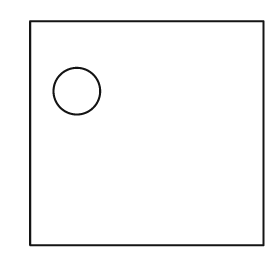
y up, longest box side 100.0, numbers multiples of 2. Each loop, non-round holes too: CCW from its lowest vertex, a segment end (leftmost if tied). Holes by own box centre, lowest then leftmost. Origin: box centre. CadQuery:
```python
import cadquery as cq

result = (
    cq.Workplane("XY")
    .moveTo(-50.0, -48.0)
    .lineTo(50.0, -48.0)
    .lineTo(50.0, 48.0)
    .lineTo(-50.0, 48.0)
    .close()
    .moveTo(-30.0, 18.0)
    .circle(10.0)
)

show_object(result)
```